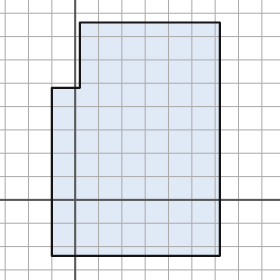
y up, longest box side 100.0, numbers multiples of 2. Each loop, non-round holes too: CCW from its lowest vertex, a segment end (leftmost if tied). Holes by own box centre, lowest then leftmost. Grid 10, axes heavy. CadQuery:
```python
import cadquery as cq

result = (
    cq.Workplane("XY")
    .moveTo(-10.0, -24.0)
    .lineTo(62.0, -24.0)
    .lineTo(62.0, 76.0)
    .lineTo(2.0, 76.0)
    .lineTo(2.0, 48.0)
    .lineTo(-10.0, 48.0)
    .close()
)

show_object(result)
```